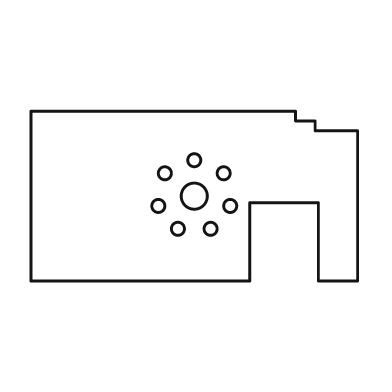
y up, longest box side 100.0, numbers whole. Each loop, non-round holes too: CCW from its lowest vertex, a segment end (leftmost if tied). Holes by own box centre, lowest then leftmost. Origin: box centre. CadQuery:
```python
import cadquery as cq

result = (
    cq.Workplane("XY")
    .moveTo(-50.0, -26.0)
    .lineTo(17.0, -26.0)
    .lineTo(17.0, -2.0)
    .lineTo(38.0, -2.0)
    .lineTo(38.0, -26.0)
    .lineTo(50.0, -26.0)
    .lineTo(50.0, 20.0)
    .lineTo(37.0, 20.0)
    .lineTo(37.0, 23.0)
    .lineTo(31.0, 23.0)
    .lineTo(31.0, 26.0)
    .lineTo(-50.0, 26.0)
    .close()
    .moveTo(-5.0, -10.0)
    .circle(2.0)
    .moveTo(5.0, -10.0)
    .circle(2.0)
    .moveTo(-11.0, -3.0)
    .circle(2.0)
    .moveTo(11.0, -3.0)
    .circle(2.0)
    .moveTo(0.0, 0.0)
    .circle(4.0)
    .moveTo(-9.0, 7.0)
    .circle(2.0)
    .moveTo(9.0, 7.0)
    .circle(2.0)
    .moveTo(0.0, 11.0)
    .circle(2.0)
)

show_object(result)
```